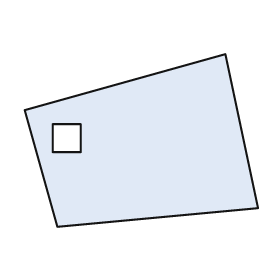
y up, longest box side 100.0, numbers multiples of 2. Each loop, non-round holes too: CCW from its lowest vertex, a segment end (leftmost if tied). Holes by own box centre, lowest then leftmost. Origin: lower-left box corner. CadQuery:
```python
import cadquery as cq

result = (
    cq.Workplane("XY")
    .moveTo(14.0, 0.0)
    .lineTo(100.0, 8.0)
    .lineTo(86.0, 74.0)
    .lineTo(0.0, 50.0)
    .close()
    .moveTo(12.0, 32.0)
    .lineTo(24.0, 32.0)
    .lineTo(24.0, 44.0)
    .lineTo(12.0, 44.0)
    .close()
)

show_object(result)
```